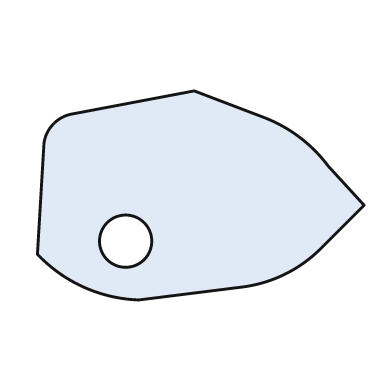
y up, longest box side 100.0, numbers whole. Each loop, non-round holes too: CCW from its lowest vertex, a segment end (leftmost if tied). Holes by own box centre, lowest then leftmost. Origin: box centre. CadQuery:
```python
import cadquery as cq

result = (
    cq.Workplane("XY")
    .moveTo(-19.0, -32.0)
    .lineTo(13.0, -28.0)
    .threePointArc((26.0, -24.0), (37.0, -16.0))
    .lineTo(50.0, -3.0)
    .lineTo(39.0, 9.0)
    .threePointArc((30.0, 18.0), (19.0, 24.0))
    .lineTo(-2.0, 32.0)
    .lineTo(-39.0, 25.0)
    .threePointArc((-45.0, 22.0), (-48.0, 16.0))
    .lineTo(-50.0, -18.0)
    .threePointArc((-36.0, -28.0), (-19.0, -32.0))
    .close()
    .moveTo(-23.0, -14.0)
    .circle(8.0)
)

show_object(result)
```